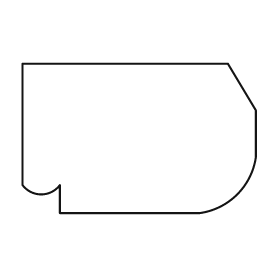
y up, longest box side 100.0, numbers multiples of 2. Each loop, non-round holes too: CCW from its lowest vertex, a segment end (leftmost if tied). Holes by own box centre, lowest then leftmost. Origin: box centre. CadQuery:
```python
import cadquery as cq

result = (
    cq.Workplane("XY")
    .moveTo(-34.0, -32.0)
    .lineTo(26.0, -32.0)
    .threePointArc((42.0, -24.0), (50.0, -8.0))
    .lineTo(50.0, 12.0)
    .lineTo(38.0, 32.0)
    .lineTo(-50.0, 32.0)
    .lineTo(-50.0, -20.0)
    .threePointArc((-42.0, -24.0), (-34.0, -20.0))
    .close()
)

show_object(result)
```